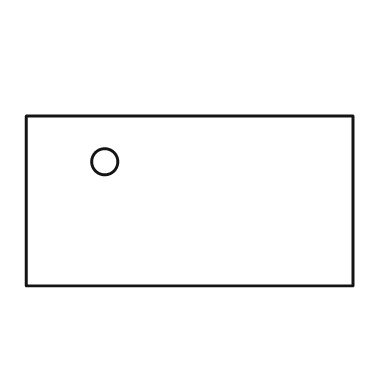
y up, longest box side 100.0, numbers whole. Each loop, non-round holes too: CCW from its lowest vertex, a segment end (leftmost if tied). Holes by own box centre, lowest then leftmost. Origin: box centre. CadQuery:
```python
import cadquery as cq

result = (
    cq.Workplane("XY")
    .moveTo(-50.0, -26.0)
    .lineTo(50.0, -26.0)
    .lineTo(50.0, 26.0)
    .lineTo(-50.0, 26.0)
    .close()
    .moveTo(-26.0, 12.0)
    .circle(4.0)
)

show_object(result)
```